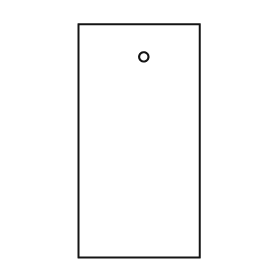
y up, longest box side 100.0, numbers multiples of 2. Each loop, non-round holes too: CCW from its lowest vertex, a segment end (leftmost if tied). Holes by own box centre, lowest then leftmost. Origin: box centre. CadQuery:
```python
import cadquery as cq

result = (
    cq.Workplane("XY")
    .moveTo(-26.0, -50.0)
    .lineTo(26.0, -50.0)
    .lineTo(26.0, 50.0)
    .lineTo(-26.0, 50.0)
    .close()
    .moveTo(2.0, 36.0)
    .circle(2.0)
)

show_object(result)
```